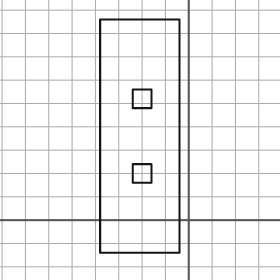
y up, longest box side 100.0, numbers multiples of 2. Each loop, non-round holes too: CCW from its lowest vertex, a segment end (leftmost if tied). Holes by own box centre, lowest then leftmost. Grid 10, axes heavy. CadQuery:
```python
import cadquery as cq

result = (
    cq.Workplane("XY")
    .moveTo(-38.0, -14.0)
    .lineTo(-4.0, -14.0)
    .lineTo(-4.0, 86.0)
    .lineTo(-38.0, 86.0)
    .close()
    .moveTo(-24.0, 16.0)
    .lineTo(-16.0, 16.0)
    .lineTo(-16.0, 24.0)
    .lineTo(-24.0, 24.0)
    .close()
    .moveTo(-24.0, 48.0)
    .lineTo(-16.0, 48.0)
    .lineTo(-16.0, 56.0)
    .lineTo(-24.0, 56.0)
    .close()
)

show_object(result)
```